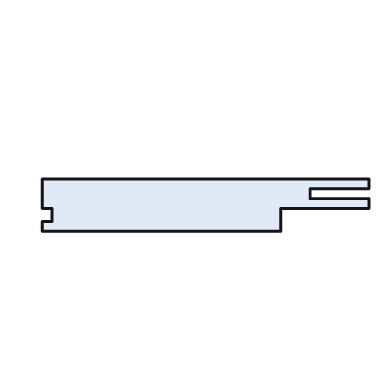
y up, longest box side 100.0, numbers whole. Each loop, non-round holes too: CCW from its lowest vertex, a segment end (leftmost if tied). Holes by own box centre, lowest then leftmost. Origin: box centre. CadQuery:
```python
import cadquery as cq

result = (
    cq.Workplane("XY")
    .moveTo(-50.0, -8.0)
    .lineTo(23.0, -8.0)
    .lineTo(23.0, -1.0)
    .lineTo(50.0, -1.0)
    .lineTo(50.0, 2.0)
    .lineTo(32.0, 2.0)
    .lineTo(32.0, 5.0)
    .lineTo(50.0, 5.0)
    .lineTo(50.0, 8.0)
    .lineTo(-50.0, 8.0)
    .lineTo(-50.0, -1.0)
    .lineTo(-47.0, -1.0)
    .lineTo(-47.0, -5.0)
    .lineTo(-50.0, -5.0)
    .close()
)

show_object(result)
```